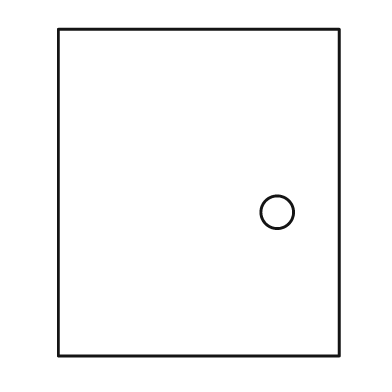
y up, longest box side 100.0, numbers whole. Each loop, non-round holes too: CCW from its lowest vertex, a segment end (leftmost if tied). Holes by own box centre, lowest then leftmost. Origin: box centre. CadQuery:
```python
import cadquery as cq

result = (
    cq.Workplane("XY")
    .moveTo(-43.0, -50.0)
    .lineTo(43.0, -50.0)
    .lineTo(43.0, 50.0)
    .lineTo(-43.0, 50.0)
    .close()
    .moveTo(24.0, -6.0)
    .circle(5.0)
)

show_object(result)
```